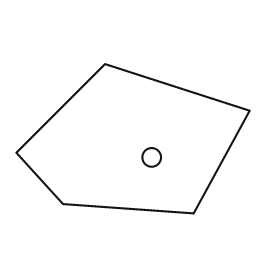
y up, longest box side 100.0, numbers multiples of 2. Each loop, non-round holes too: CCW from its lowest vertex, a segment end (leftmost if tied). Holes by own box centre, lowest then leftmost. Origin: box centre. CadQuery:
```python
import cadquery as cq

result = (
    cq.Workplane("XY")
    .moveTo(26.0, -32.0)
    .lineTo(50.0, 12.0)
    .lineTo(-12.0, 32.0)
    .lineTo(-50.0, -6.0)
    .lineTo(-30.0, -28.0)
    .close()
    .moveTo(8.0, -8.0)
    .circle(4.0)
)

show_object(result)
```